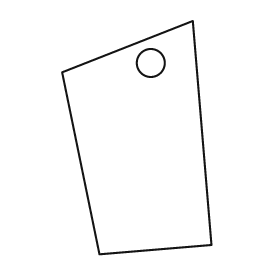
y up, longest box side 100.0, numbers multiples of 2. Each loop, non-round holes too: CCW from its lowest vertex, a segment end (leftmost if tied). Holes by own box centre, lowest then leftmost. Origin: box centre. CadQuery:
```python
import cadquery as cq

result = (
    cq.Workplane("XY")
    .moveTo(-16.0, -50.0)
    .lineTo(32.0, -46.0)
    .lineTo(24.0, 50.0)
    .lineTo(-32.0, 28.0)
    .close()
    .moveTo(6.0, 32.0)
    .circle(6.0)
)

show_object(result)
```